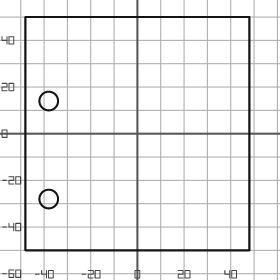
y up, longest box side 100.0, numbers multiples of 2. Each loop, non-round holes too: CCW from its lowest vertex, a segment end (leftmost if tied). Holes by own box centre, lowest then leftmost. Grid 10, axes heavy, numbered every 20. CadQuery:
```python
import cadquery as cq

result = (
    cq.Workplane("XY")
    .moveTo(-48.0, -50.0)
    .lineTo(48.0, -50.0)
    .lineTo(48.0, 50.0)
    .lineTo(-48.0, 50.0)
    .close()
    .moveTo(-38.0, -28.0)
    .circle(4.0)
    .moveTo(-38.0, 14.0)
    .circle(4.0)
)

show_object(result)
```